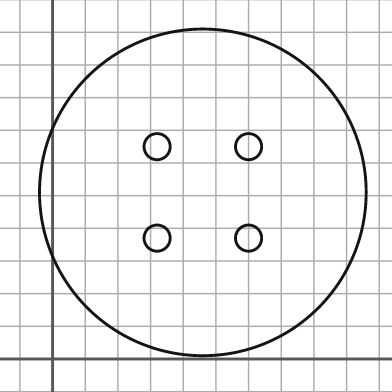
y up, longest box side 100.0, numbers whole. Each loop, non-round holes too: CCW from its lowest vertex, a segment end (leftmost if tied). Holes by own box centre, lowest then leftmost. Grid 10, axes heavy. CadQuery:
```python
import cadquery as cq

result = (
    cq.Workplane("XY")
    .moveTo(46.0, 51.0)
    .circle(50.0)
    .moveTo(32.0, 37.0)
    .circle(4.0)
    .moveTo(60.0, 37.0)
    .circle(4.0)
    .moveTo(32.0, 65.0)
    .circle(4.0)
    .moveTo(60.0, 65.0)
    .circle(4.0)
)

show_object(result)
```